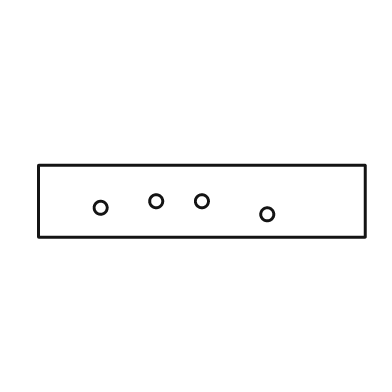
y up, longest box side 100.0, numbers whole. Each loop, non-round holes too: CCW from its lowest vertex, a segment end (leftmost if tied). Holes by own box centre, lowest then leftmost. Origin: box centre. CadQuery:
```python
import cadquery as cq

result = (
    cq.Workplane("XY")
    .moveTo(-50.0, -11.0)
    .lineTo(50.0, -11.0)
    .lineTo(50.0, 11.0)
    .lineTo(-50.0, 11.0)
    .close()
    .moveTo(20.0, -4.0)
    .circle(2.0)
    .moveTo(-31.0, -2.0)
    .circle(2.0)
    .moveTo(-14.0, 0.0)
    .circle(2.0)
    .moveTo(0.0, 0.0)
    .circle(2.0)
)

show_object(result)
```